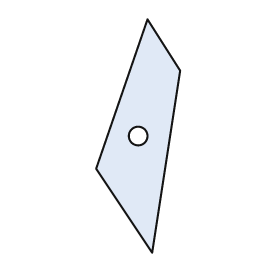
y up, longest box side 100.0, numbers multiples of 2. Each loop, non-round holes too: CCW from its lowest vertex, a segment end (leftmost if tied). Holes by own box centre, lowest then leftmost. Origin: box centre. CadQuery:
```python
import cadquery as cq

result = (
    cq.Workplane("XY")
    .moveTo(6.0, -50.0)
    .lineTo(18.0, 28.0)
    .lineTo(4.0, 50.0)
    .lineTo(-18.0, -14.0)
    .close()
    .moveTo(0.0, 0.0)
    .circle(4.0)
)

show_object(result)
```